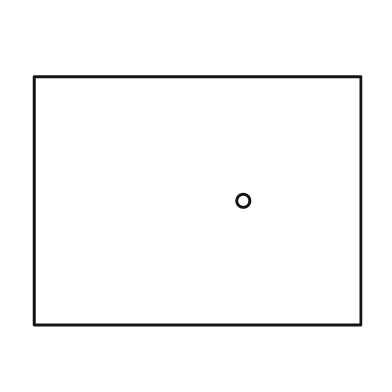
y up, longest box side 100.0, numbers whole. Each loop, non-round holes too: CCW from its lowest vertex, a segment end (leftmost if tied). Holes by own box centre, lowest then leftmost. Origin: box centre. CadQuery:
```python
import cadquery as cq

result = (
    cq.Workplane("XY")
    .moveTo(-50.0, -38.0)
    .lineTo(50.0, -38.0)
    .lineTo(50.0, 38.0)
    .lineTo(-50.0, 38.0)
    .close()
    .moveTo(14.0, 0.0)
    .circle(2.0)
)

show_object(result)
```